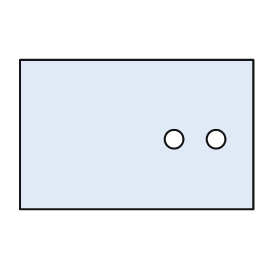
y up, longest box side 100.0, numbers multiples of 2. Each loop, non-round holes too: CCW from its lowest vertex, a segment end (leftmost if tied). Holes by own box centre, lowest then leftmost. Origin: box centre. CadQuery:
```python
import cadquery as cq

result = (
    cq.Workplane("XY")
    .moveTo(-50.0, -32.0)
    .lineTo(50.0, -32.0)
    .lineTo(50.0, 32.0)
    .lineTo(-50.0, 32.0)
    .close()
    .moveTo(16.0, -2.0)
    .circle(4.0)
    .moveTo(34.0, -2.0)
    .circle(4.0)
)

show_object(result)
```